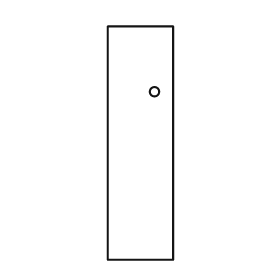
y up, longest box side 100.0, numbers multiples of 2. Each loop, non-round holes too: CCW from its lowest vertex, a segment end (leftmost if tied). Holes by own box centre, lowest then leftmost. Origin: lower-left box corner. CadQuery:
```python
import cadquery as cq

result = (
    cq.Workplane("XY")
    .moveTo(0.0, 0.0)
    .lineTo(28.0, 0.0)
    .lineTo(28.0, 100.0)
    .lineTo(0.0, 100.0)
    .close()
    .moveTo(20.0, 72.0)
    .circle(2.0)
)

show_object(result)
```